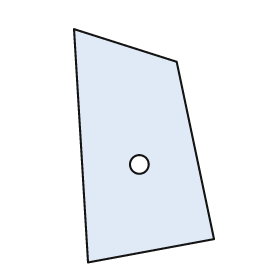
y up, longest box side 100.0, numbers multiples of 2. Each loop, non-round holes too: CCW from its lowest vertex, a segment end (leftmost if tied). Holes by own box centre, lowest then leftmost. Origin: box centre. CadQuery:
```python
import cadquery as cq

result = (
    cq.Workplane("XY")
    .moveTo(-24.0, -50.0)
    .lineTo(30.0, -40.0)
    .lineTo(14.0, 36.0)
    .lineTo(-30.0, 50.0)
    .close()
    .moveTo(-2.0, -8.0)
    .circle(4.0)
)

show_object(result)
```